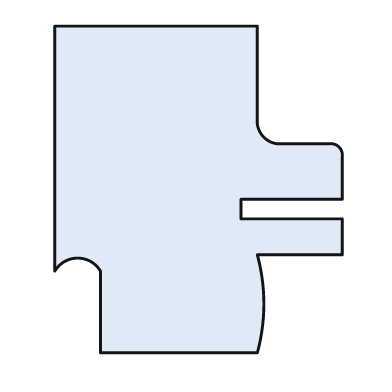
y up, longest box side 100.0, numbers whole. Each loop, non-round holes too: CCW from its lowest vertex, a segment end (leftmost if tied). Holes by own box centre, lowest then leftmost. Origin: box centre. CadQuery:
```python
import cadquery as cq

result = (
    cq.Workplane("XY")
    .moveTo(-30.0, -50.0)
    .lineTo(18.0, -50.0)
    .threePointArc((20.0, -35.0), (18.0, -20.0))
    .lineTo(44.0, -20.0)
    .lineTo(44.0, -9.0)
    .lineTo(13.0, -9.0)
    .lineTo(13.0, -3.0)
    .lineTo(44.0, -3.0)
    .lineTo(44.0, 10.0)
    .threePointArc((43.0, 13.0), (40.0, 14.0))
    .lineTo(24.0, 14.0)
    .threePointArc((20.0, 16.0), (18.0, 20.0))
    .lineTo(18.0, 50.0)
    .lineTo(-44.0, 50.0)
    .lineTo(-44.0, -25.0)
    .threePointArc((-37.0, -21.0), (-30.0, -25.0))
    .close()
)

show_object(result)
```